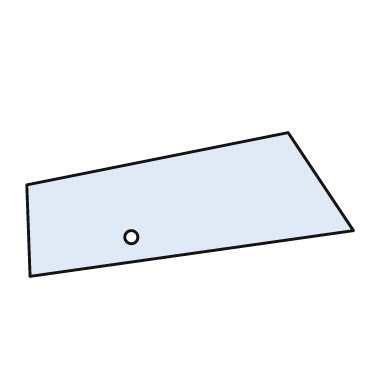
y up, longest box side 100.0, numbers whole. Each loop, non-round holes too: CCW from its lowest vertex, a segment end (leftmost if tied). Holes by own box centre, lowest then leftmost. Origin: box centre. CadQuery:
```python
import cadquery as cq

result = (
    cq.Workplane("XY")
    .moveTo(-49.0, -22.0)
    .lineTo(50.0, -8.0)
    .lineTo(30.0, 22.0)
    .lineTo(-50.0, 6.0)
    .close()
    .moveTo(-18.0, -10.0)
    .circle(2.0)
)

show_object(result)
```